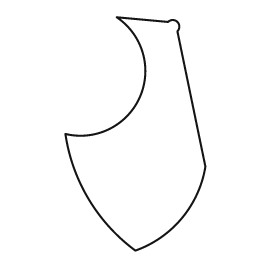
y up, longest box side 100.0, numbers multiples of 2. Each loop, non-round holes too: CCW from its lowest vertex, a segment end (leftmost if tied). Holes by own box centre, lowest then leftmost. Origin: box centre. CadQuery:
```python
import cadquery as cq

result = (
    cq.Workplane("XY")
    .moveTo(0.0, -50.0)
    .threePointArc((20.0, -36.0), (30.0, -14.0))
    .lineTo(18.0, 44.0)
    .threePointArc((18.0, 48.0), (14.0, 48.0))
    .lineTo(-8.0, 50.0)
    .threePointArc((2.0, 16.0), (-30.0, 0.0))
    .threePointArc((-20.0, -28.0), (0.0, -50.0))
    .close()
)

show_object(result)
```